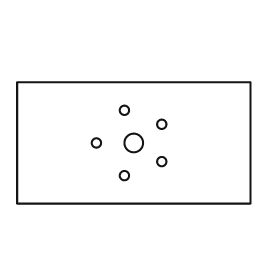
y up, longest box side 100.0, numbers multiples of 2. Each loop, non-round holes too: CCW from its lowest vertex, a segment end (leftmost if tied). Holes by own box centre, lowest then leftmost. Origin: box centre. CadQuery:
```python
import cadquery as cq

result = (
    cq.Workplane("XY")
    .moveTo(-50.0, -26.0)
    .lineTo(50.0, -26.0)
    .lineTo(50.0, 26.0)
    .lineTo(-50.0, 26.0)
    .close()
    .moveTo(-4.0, -14.0)
    .circle(2.0)
    .moveTo(12.0, -8.0)
    .circle(2.0)
    .moveTo(-16.0, 0.0)
    .circle(2.0)
    .moveTo(0.0, 0.0)
    .circle(4.0)
    .moveTo(12.0, 8.0)
    .circle(2.0)
    .moveTo(-4.0, 14.0)
    .circle(2.0)
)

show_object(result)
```